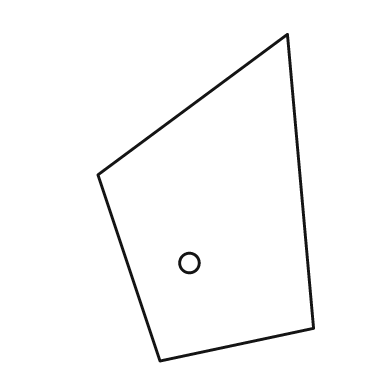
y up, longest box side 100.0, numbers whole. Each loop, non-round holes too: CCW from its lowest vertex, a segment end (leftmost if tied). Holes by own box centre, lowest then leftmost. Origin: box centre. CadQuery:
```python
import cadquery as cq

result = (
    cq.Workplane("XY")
    .moveTo(-14.0, -50.0)
    .lineTo(33.0, -40.0)
    .lineTo(25.0, 50.0)
    .lineTo(-33.0, 7.0)
    .close()
    .moveTo(-5.0, -20.0)
    .circle(3.0)
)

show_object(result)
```